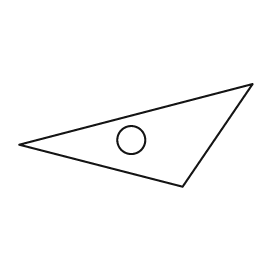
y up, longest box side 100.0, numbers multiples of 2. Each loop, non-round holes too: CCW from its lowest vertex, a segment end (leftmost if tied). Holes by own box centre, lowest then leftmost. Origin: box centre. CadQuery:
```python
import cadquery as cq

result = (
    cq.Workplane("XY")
    .moveTo(20.0, -22.0)
    .lineTo(50.0, 22.0)
    .lineTo(-50.0, -4.0)
    .close()
    .moveTo(-2.0, -2.0)
    .circle(6.0)
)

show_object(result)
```